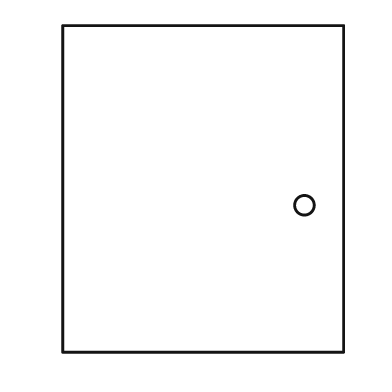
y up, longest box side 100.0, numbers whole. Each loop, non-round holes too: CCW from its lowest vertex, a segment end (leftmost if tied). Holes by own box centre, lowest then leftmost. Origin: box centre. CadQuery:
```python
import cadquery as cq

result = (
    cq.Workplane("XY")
    .moveTo(-43.0, -50.0)
    .lineTo(43.0, -50.0)
    .lineTo(43.0, 50.0)
    .lineTo(-43.0, 50.0)
    .close()
    .moveTo(31.0, -5.0)
    .circle(3.0)
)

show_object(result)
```